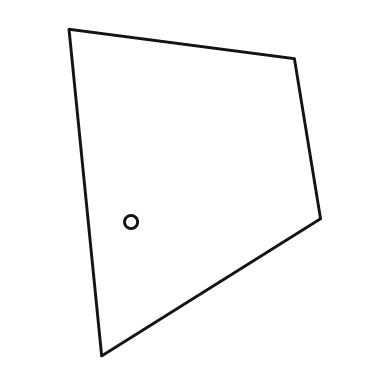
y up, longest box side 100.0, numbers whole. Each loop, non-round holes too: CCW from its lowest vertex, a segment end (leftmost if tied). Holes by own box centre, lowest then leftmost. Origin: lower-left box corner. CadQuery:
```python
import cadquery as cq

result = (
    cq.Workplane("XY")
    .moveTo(10.0, 0.0)
    .lineTo(77.0, 42.0)
    .lineTo(69.0, 91.0)
    .lineTo(0.0, 100.0)
    .close()
    .moveTo(19.0, 41.0)
    .circle(2.0)
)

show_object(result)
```